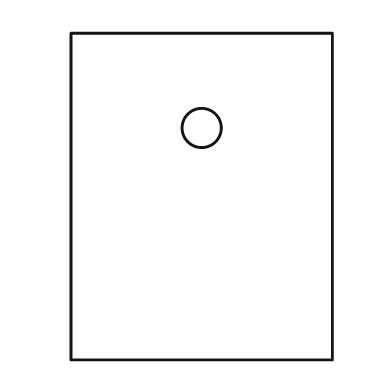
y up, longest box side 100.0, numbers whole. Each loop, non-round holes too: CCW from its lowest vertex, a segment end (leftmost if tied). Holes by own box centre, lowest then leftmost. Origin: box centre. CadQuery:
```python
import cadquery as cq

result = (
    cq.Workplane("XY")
    .moveTo(-40.0, -50.0)
    .lineTo(40.0, -50.0)
    .lineTo(40.0, 50.0)
    .lineTo(-40.0, 50.0)
    .close()
    .moveTo(0.0, 21.0)
    .circle(6.0)
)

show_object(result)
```